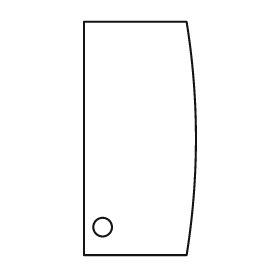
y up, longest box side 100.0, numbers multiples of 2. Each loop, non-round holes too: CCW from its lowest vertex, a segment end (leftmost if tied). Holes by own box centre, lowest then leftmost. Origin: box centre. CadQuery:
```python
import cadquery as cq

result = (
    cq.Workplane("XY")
    .moveTo(-24.0, -50.0)
    .lineTo(20.0, -50.0)
    .threePointArc((24.0, 0.0), (20.0, 50.0))
    .lineTo(-24.0, 50.0)
    .close()
    .moveTo(-16.0, -38.0)
    .circle(4.0)
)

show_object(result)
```